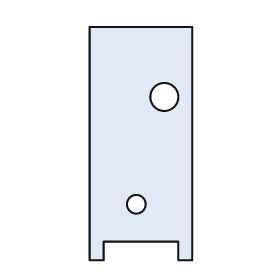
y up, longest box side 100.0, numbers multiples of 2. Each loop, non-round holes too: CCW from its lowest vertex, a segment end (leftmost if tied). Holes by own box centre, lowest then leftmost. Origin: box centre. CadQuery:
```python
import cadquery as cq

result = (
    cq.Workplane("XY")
    .moveTo(-22.0, -50.0)
    .lineTo(-16.0, -50.0)
    .lineTo(-16.0, -42.0)
    .lineTo(16.0, -42.0)
    .lineTo(16.0, -50.0)
    .lineTo(22.0, -50.0)
    .lineTo(22.0, 50.0)
    .lineTo(-22.0, 50.0)
    .close()
    .moveTo(-2.0, -26.0)
    .circle(4.0)
    .moveTo(10.0, 20.0)
    .circle(6.0)
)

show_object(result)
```